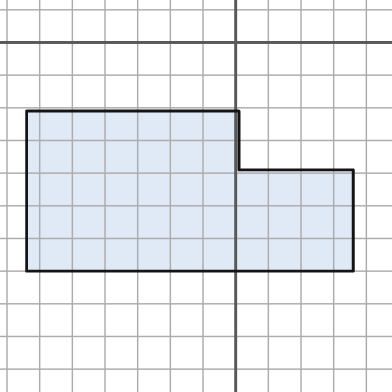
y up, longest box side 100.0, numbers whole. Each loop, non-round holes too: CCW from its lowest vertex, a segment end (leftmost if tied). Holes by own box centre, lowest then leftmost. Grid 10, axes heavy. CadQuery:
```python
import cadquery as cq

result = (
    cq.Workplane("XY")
    .moveTo(-64.0, -70.0)
    .lineTo(36.0, -70.0)
    .lineTo(36.0, -39.0)
    .lineTo(1.0, -39.0)
    .lineTo(1.0, -21.0)
    .lineTo(-64.0, -21.0)
    .close()
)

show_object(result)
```